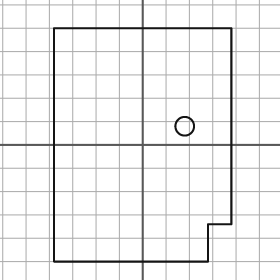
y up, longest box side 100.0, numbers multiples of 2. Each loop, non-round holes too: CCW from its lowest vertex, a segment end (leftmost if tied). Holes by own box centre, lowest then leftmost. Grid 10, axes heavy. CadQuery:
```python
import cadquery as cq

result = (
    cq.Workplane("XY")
    .moveTo(-38.0, -50.0)
    .lineTo(28.0, -50.0)
    .lineTo(28.0, -34.0)
    .lineTo(38.0, -34.0)
    .lineTo(38.0, 50.0)
    .lineTo(-38.0, 50.0)
    .close()
    .moveTo(18.0, 8.0)
    .circle(4.0)
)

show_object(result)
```